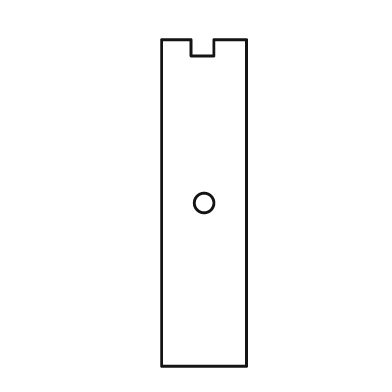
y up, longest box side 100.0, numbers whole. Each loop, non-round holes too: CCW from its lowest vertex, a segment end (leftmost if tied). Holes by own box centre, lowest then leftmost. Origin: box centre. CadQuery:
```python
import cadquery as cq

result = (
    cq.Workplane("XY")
    .moveTo(-13.0, -50.0)
    .lineTo(13.0, -50.0)
    .lineTo(13.0, 50.0)
    .lineTo(3.0, 50.0)
    .lineTo(3.0, 45.0)
    .lineTo(-4.0, 45.0)
    .lineTo(-4.0, 50.0)
    .lineTo(-13.0, 50.0)
    .close()
    .moveTo(0.0, 0.0)
    .circle(3.0)
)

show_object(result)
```